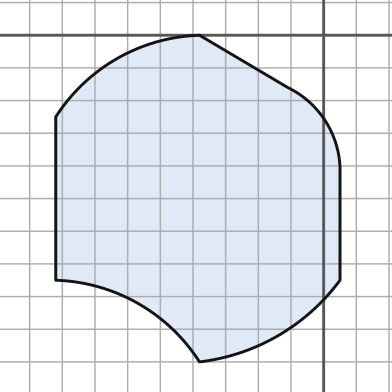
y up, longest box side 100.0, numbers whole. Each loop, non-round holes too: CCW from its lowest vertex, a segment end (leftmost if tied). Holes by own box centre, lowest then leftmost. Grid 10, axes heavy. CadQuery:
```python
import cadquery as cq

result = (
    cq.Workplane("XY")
    .moveTo(-38.0, -100.0)
    .threePointArc((-14.0, -92.0), (5.0, -75.0))
    .lineTo(5.0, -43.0)
    .threePointArc((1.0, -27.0), (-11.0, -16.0))
    .lineTo(-38.0, 0.0)
    .threePointArc((-63.0, -7.0), (-82.0, -25.0))
    .lineTo(-82.0, -75.0)
    .threePointArc((-57.0, -82.0), (-38.0, -100.0))
    .close()
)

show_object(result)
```